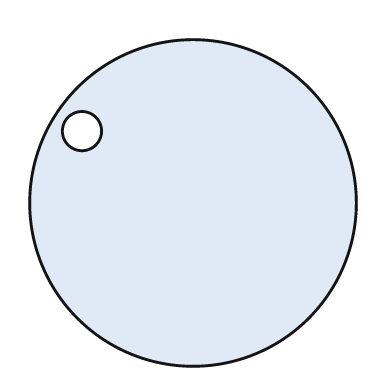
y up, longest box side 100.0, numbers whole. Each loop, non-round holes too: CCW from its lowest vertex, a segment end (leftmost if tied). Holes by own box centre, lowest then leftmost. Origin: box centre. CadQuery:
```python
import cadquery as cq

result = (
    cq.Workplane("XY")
    .moveTo(0.0, 0.0)
    .circle(50.0)
    .moveTo(-34.0, 22.0)
    .circle(6.0)
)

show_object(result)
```